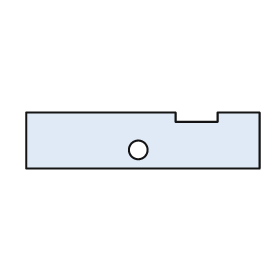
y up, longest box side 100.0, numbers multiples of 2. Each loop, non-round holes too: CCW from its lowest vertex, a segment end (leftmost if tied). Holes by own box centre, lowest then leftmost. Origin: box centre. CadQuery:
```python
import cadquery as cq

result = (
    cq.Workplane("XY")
    .moveTo(-50.0, -12.0)
    .lineTo(50.0, -12.0)
    .lineTo(50.0, 12.0)
    .lineTo(32.0, 12.0)
    .lineTo(32.0, 8.0)
    .lineTo(14.0, 8.0)
    .lineTo(14.0, 12.0)
    .lineTo(-50.0, 12.0)
    .close()
    .moveTo(-2.0, -4.0)
    .circle(4.0)
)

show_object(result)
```